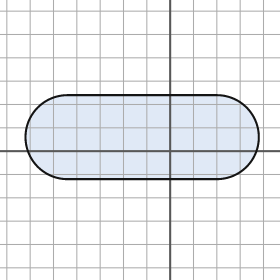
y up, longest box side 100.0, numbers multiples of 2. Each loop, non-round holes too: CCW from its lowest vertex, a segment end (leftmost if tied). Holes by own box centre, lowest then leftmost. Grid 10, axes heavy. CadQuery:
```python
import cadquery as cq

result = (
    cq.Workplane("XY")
    .moveTo(-44.0, -12.0)
    .lineTo(20.0, -12.0)
    .threePointArc((38.0, 6.0), (20.0, 24.0))
    .lineTo(-44.0, 24.0)
    .threePointArc((-62.0, 6.0), (-44.0, -12.0))
    .close()
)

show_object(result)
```